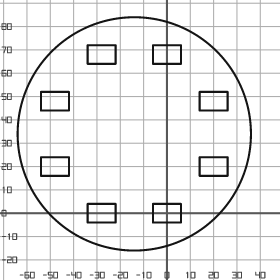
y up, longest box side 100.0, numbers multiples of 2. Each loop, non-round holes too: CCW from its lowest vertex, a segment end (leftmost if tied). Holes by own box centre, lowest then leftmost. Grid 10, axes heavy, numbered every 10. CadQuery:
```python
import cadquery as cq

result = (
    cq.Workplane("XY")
    .moveTo(-14.0, 34.0)
    .circle(50.0)
    .moveTo(-34.0, -4.0)
    .lineTo(-22.0, -4.0)
    .lineTo(-22.0, 4.0)
    .lineTo(-34.0, 4.0)
    .close()
    .moveTo(-6.0, -4.0)
    .lineTo(6.0, -4.0)
    .lineTo(6.0, 4.0)
    .lineTo(-6.0, 4.0)
    .close()
    .moveTo(-54.0, 16.0)
    .lineTo(-42.0, 16.0)
    .lineTo(-42.0, 24.0)
    .lineTo(-54.0, 24.0)
    .close()
    .moveTo(14.0, 16.0)
    .lineTo(26.0, 16.0)
    .lineTo(26.0, 24.0)
    .lineTo(14.0, 24.0)
    .close()
    .moveTo(-54.0, 44.0)
    .lineTo(-42.0, 44.0)
    .lineTo(-42.0, 52.0)
    .lineTo(-54.0, 52.0)
    .close()
    .moveTo(14.0, 44.0)
    .lineTo(26.0, 44.0)
    .lineTo(26.0, 52.0)
    .lineTo(14.0, 52.0)
    .close()
    .moveTo(-34.0, 64.0)
    .lineTo(-22.0, 64.0)
    .lineTo(-22.0, 72.0)
    .lineTo(-34.0, 72.0)
    .close()
    .moveTo(-6.0, 64.0)
    .lineTo(6.0, 64.0)
    .lineTo(6.0, 72.0)
    .lineTo(-6.0, 72.0)
    .close()
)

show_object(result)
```